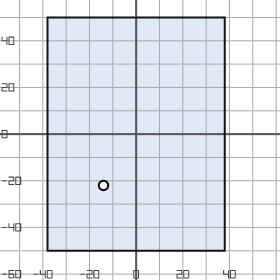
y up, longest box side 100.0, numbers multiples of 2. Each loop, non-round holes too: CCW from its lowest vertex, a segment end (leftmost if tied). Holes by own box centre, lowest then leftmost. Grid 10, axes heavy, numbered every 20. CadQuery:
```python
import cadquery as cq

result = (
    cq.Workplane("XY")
    .moveTo(-38.0, -50.0)
    .lineTo(38.0, -50.0)
    .lineTo(38.0, 50.0)
    .lineTo(-38.0, 50.0)
    .close()
    .moveTo(-14.0, -22.0)
    .circle(2.0)
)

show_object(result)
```